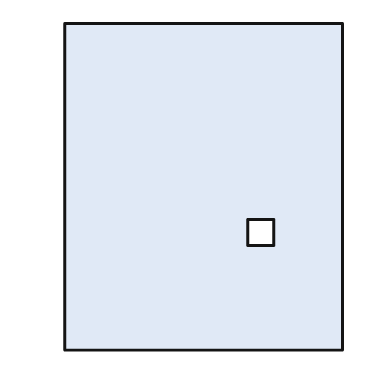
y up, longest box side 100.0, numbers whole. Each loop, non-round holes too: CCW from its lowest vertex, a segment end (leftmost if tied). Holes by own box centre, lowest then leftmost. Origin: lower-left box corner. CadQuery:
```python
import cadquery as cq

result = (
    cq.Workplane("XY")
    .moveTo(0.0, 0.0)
    .lineTo(85.0, 0.0)
    .lineTo(85.0, 100.0)
    .lineTo(0.0, 100.0)
    .close()
    .moveTo(56.0, 32.0)
    .lineTo(64.0, 32.0)
    .lineTo(64.0, 40.0)
    .lineTo(56.0, 40.0)
    .close()
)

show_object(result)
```